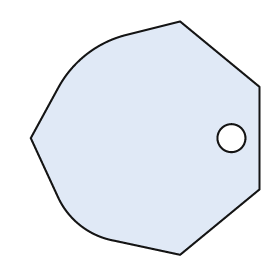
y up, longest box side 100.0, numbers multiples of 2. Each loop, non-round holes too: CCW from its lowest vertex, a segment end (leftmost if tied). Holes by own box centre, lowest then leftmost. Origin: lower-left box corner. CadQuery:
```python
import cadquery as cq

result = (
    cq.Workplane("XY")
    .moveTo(64.0, 0.0)
    .lineTo(98.0, 28.0)
    .lineTo(98.0, 72.0)
    .lineTo(64.0, 100.0)
    .lineTo(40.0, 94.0)
    .threePointArc((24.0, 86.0), (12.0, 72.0))
    .lineTo(0.0, 50.0)
    .lineTo(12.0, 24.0)
    .threePointArc((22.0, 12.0), (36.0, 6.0))
    .close()
    .moveTo(86.0, 50.0)
    .circle(6.0)
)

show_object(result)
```